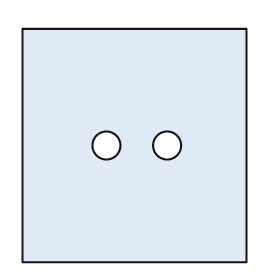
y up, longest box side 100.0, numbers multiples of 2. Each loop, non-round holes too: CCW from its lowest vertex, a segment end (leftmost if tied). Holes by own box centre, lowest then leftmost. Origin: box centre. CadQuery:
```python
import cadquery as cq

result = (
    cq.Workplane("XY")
    .moveTo(-48.0, -50.0)
    .lineTo(48.0, -50.0)
    .lineTo(48.0, 50.0)
    .lineTo(-48.0, 50.0)
    .close()
    .moveTo(-12.0, 0.0)
    .circle(6.0)
    .moveTo(14.0, 0.0)
    .circle(6.0)
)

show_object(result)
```